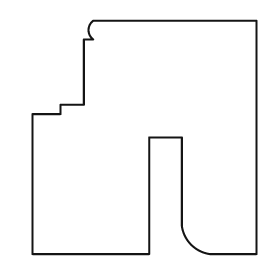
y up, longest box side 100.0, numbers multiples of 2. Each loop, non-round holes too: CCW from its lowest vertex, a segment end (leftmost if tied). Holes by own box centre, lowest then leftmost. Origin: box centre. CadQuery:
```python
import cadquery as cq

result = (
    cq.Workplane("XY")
    .moveTo(-48.0, -50.0)
    .lineTo(2.0, -50.0)
    .lineTo(2.0, 0.0)
    .lineTo(16.0, 0.0)
    .lineTo(16.0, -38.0)
    .threePointArc((20.0, -46.0), (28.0, -50.0))
    .lineTo(48.0, -50.0)
    .lineTo(48.0, 50.0)
    .lineTo(-22.0, 50.0)
    .threePointArc((-24.0, 46.0), (-22.0, 42.0))
    .lineTo(-26.0, 42.0)
    .lineTo(-26.0, 14.0)
    .lineTo(-36.0, 14.0)
    .lineTo(-36.0, 10.0)
    .lineTo(-48.0, 10.0)
    .close()
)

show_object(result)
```